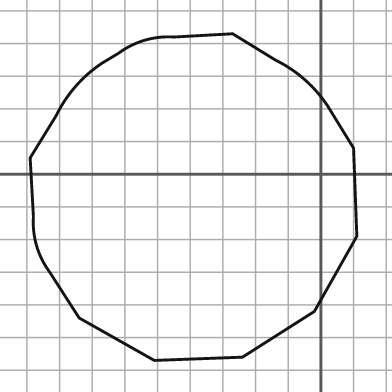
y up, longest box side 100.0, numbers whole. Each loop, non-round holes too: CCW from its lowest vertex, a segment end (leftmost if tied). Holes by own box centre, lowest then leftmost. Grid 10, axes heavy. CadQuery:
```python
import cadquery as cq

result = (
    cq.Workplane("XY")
    .moveTo(-51.0, -57.0)
    .lineTo(-24.0, -56.0)
    .lineTo(-2.0, -42.0)
    .lineTo(11.0, -19.0)
    .lineTo(10.0, 8.0)
    .lineTo(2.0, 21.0)
    .threePointArc((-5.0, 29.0), (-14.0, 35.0))
    .lineTo(-27.0, 43.0)
    .lineTo(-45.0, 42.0)
    .threePointArc((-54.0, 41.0), (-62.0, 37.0))
    .lineTo(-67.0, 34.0)
    .threePointArc((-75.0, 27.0), (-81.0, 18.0))
    .lineTo(-89.0, 5.0)
    .lineTo(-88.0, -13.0)
    .threePointArc((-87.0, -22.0), (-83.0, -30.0))
    .lineTo(-74.0, -44.0)
    .close()
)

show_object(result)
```